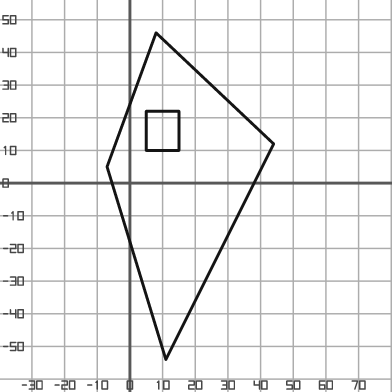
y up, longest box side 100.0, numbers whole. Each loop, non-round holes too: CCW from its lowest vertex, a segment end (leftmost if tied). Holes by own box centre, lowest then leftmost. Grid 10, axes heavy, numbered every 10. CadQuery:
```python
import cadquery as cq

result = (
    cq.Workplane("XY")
    .moveTo(11.0, -54.0)
    .lineTo(44.0, 12.0)
    .lineTo(8.0, 46.0)
    .lineTo(-7.0, 5.0)
    .close()
    .moveTo(5.0, 10.0)
    .lineTo(15.0, 10.0)
    .lineTo(15.0, 22.0)
    .lineTo(5.0, 22.0)
    .close()
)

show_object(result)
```